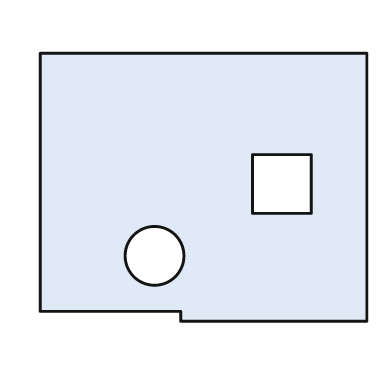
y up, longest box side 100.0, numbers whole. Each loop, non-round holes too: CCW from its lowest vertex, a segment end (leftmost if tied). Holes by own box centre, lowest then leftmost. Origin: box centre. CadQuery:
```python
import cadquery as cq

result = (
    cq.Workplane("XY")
    .moveTo(-7.0, -41.0)
    .lineTo(50.0, -41.0)
    .lineTo(50.0, 41.0)
    .lineTo(-50.0, 41.0)
    .lineTo(-50.0, -38.0)
    .lineTo(-7.0, -38.0)
    .close()
    .moveTo(-15.0, -21.0)
    .circle(9.0)
    .moveTo(15.0, -8.0)
    .lineTo(33.0, -8.0)
    .lineTo(33.0, 10.0)
    .lineTo(15.0, 10.0)
    .close()
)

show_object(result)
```